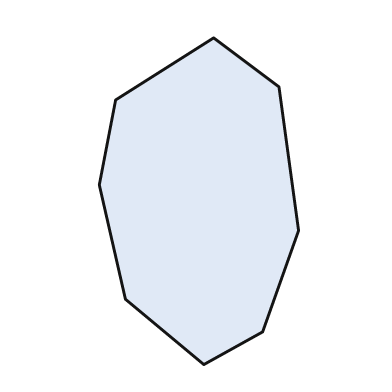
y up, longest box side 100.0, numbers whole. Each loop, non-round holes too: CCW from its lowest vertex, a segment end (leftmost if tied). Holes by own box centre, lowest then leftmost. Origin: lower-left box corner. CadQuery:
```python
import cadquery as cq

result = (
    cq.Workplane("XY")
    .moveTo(32.0, 0.0)
    .lineTo(50.0, 10.0)
    .lineTo(61.0, 41.0)
    .lineTo(55.0, 85.0)
    .lineTo(35.0, 100.0)
    .lineTo(5.0, 81.0)
    .lineTo(0.0, 55.0)
    .lineTo(8.0, 20.0)
    .close()
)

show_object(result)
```